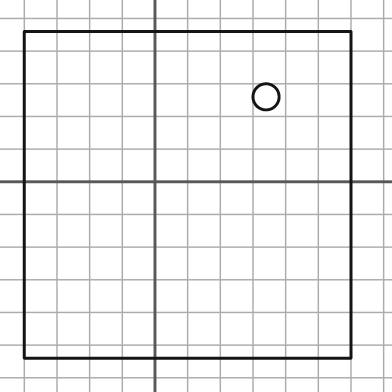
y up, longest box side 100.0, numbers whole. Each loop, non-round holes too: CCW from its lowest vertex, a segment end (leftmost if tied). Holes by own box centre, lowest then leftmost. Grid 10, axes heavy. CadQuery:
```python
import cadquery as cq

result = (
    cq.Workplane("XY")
    .moveTo(-40.0, -54.0)
    .lineTo(60.0, -54.0)
    .lineTo(60.0, 46.0)
    .lineTo(-40.0, 46.0)
    .close()
    .moveTo(34.0, 26.0)
    .circle(4.0)
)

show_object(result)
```